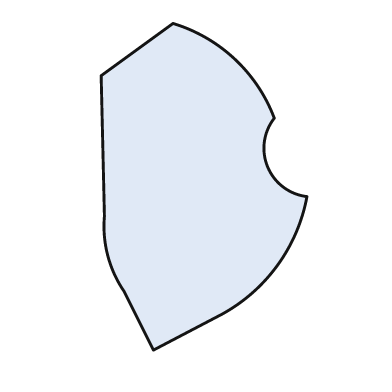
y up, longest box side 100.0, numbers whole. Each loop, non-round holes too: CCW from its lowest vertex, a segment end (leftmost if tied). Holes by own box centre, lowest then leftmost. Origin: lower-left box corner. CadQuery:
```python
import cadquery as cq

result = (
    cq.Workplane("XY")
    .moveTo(16.0, 0.0)
    .lineTo(37.0, 11.0)
    .threePointArc((54.0, 26.0), (63.0, 47.0))
    .threePointArc((51.0, 56.0), (53.0, 71.0))
    .threePointArc((41.0, 89.0), (22.0, 100.0))
    .lineTo(0.0, 84.0)
    .lineTo(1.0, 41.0)
    .threePointArc((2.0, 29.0), (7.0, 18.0))
    .close()
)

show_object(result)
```